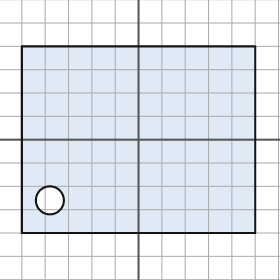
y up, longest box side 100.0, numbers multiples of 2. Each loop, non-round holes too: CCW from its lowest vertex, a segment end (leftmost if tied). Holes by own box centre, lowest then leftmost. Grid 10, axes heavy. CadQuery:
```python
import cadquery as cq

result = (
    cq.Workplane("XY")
    .moveTo(-50.0, -40.0)
    .lineTo(50.0, -40.0)
    .lineTo(50.0, 40.0)
    .lineTo(-50.0, 40.0)
    .close()
    .moveTo(-38.0, -26.0)
    .circle(6.0)
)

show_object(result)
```